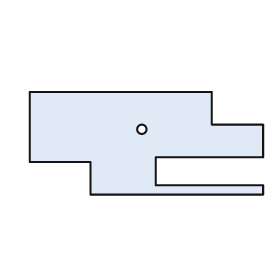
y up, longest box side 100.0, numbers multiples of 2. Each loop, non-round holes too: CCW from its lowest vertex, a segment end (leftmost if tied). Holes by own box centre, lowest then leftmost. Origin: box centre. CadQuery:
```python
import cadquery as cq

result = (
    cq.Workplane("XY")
    .moveTo(-24.0, -22.0)
    .lineTo(50.0, -22.0)
    .lineTo(50.0, -18.0)
    .lineTo(4.0, -18.0)
    .lineTo(4.0, -6.0)
    .lineTo(50.0, -6.0)
    .lineTo(50.0, 8.0)
    .lineTo(28.0, 8.0)
    .lineTo(28.0, 22.0)
    .lineTo(-50.0, 22.0)
    .lineTo(-50.0, -8.0)
    .lineTo(-24.0, -8.0)
    .close()
    .moveTo(-2.0, 6.0)
    .circle(2.0)
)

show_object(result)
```